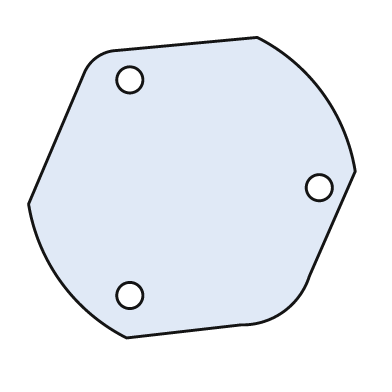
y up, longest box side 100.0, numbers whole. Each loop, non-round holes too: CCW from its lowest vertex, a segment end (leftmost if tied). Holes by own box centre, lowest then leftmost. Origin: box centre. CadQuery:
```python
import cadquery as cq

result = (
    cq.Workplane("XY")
    .moveTo(-20.0, -46.0)
    .lineTo(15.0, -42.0)
    .threePointArc((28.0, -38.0), (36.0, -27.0))
    .lineTo(50.0, 5.0)
    .threePointArc((40.0, 29.0), (20.0, 46.0))
    .lineTo(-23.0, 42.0)
    .threePointArc((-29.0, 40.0), (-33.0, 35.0))
    .lineTo(-50.0, -5.0)
    .threePointArc((-40.0, -29.0), (-20.0, -46.0))
    .close()
    .moveTo(-19.0, -33.0)
    .circle(4.0)
    .moveTo(39.0, 0.0)
    .circle(4.0)
    .moveTo(-19.0, 33.0)
    .circle(4.0)
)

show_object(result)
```